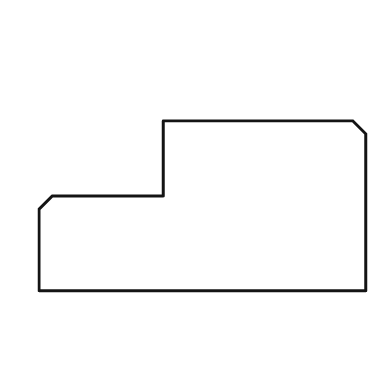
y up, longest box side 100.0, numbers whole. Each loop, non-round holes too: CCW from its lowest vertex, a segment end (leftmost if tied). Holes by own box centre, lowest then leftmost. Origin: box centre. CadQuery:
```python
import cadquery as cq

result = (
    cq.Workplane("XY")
    .moveTo(-50.0, -26.0)
    .lineTo(50.0, -26.0)
    .lineTo(50.0, 22.0)
    .lineTo(46.0, 26.0)
    .lineTo(-12.0, 26.0)
    .lineTo(-12.0, 3.0)
    .lineTo(-46.0, 3.0)
    .lineTo(-50.0, -1.0)
    .close()
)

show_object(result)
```